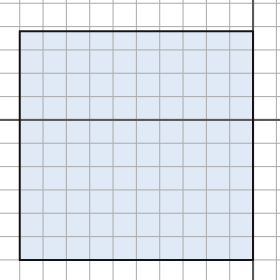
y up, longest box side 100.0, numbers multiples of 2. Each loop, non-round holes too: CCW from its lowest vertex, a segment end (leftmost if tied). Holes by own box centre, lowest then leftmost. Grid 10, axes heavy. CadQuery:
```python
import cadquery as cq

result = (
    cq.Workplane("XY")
    .moveTo(-100.0, -60.0)
    .lineTo(0.0, -60.0)
    .lineTo(0.0, 38.0)
    .lineTo(-100.0, 38.0)
    .close()
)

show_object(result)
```